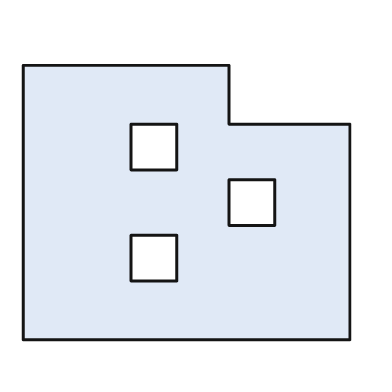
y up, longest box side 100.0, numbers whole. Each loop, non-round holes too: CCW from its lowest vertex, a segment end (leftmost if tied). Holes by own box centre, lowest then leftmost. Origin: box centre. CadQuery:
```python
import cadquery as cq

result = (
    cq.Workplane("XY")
    .moveTo(-50.0, -42.0)
    .lineTo(50.0, -42.0)
    .lineTo(50.0, 24.0)
    .lineTo(13.0, 24.0)
    .lineTo(13.0, 42.0)
    .lineTo(-50.0, 42.0)
    .close()
    .moveTo(-17.0, -24.0)
    .lineTo(-3.0, -24.0)
    .lineTo(-3.0, -10.0)
    .lineTo(-17.0, -10.0)
    .close()
    .moveTo(13.0, -7.0)
    .lineTo(27.0, -7.0)
    .lineTo(27.0, 7.0)
    .lineTo(13.0, 7.0)
    .close()
    .moveTo(-17.0, 10.0)
    .lineTo(-3.0, 10.0)
    .lineTo(-3.0, 24.0)
    .lineTo(-17.0, 24.0)
    .close()
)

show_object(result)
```